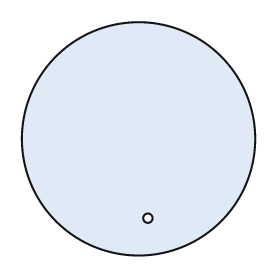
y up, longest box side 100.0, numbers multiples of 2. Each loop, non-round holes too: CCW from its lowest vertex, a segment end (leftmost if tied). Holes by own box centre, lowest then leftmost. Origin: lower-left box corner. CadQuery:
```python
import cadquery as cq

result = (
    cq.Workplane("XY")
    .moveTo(50.0, 50.0)
    .circle(50.0)
    .moveTo(54.0, 16.0)
    .circle(2.0)
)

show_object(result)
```